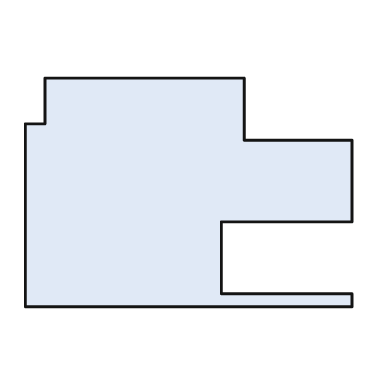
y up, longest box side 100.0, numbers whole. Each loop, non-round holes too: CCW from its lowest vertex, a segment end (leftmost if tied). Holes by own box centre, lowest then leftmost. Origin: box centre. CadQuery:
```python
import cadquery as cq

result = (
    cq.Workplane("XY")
    .moveTo(-50.0, -35.0)
    .lineTo(50.0, -35.0)
    .lineTo(50.0, -31.0)
    .lineTo(10.0, -31.0)
    .lineTo(10.0, -9.0)
    .lineTo(50.0, -9.0)
    .lineTo(50.0, 16.0)
    .lineTo(17.0, 16.0)
    .lineTo(17.0, 35.0)
    .lineTo(-44.0, 35.0)
    .lineTo(-44.0, 21.0)
    .lineTo(-50.0, 21.0)
    .close()
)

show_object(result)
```